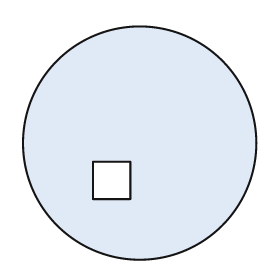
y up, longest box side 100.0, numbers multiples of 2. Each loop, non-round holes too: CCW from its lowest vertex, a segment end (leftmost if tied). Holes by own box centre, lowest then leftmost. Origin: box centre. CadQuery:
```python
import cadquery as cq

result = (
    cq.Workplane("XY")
    .moveTo(0.0, 0.0)
    .circle(50.0)
    .moveTo(-20.0, -24.0)
    .lineTo(-4.0, -24.0)
    .lineTo(-4.0, -8.0)
    .lineTo(-20.0, -8.0)
    .close()
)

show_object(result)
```